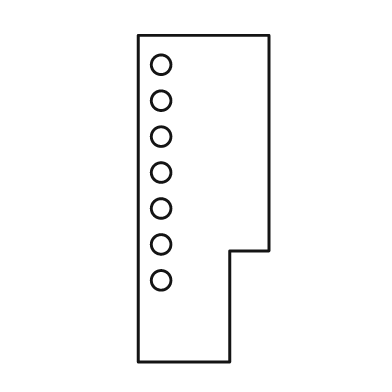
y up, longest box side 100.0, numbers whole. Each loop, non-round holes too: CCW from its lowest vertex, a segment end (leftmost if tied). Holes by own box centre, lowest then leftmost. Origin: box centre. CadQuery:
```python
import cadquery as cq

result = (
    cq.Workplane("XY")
    .moveTo(-20.0, -50.0)
    .lineTo(8.0, -50.0)
    .lineTo(8.0, -16.0)
    .lineTo(20.0, -16.0)
    .lineTo(20.0, 50.0)
    .lineTo(-20.0, 50.0)
    .close()
    .moveTo(-13.0, -25.0)
    .circle(3.0)
    .moveTo(-13.0, -14.0)
    .circle(3.0)
    .moveTo(-13.0, -3.0)
    .circle(3.0)
    .moveTo(-13.0, 8.0)
    .circle(3.0)
    .moveTo(-13.0, 19.0)
    .circle(3.0)
    .moveTo(-13.0, 30.0)
    .circle(3.0)
    .moveTo(-13.0, 41.0)
    .circle(3.0)
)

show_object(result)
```